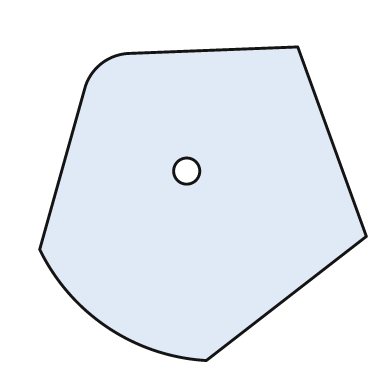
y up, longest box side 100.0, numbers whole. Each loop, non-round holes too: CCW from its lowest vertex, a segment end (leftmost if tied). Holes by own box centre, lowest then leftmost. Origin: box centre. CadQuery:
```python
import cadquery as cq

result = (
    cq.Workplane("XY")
    .moveTo(1.0, -48.0)
    .lineTo(50.0, -10.0)
    .lineTo(29.0, 48.0)
    .lineTo(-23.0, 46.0)
    .threePointArc((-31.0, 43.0), (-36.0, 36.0))
    .lineTo(-50.0, -14.0)
    .threePointArc((-29.0, -38.0), (1.0, -48.0))
    .close()
    .moveTo(-5.0, 10.0)
    .circle(4.0)
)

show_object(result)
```